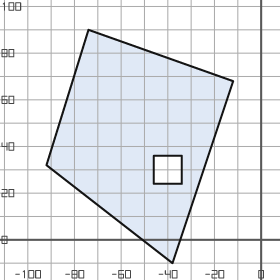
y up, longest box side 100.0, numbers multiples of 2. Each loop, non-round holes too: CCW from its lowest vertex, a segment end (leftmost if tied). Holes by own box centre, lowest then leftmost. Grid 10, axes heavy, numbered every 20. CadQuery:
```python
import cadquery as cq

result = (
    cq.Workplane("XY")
    .moveTo(-38.0, -10.0)
    .lineTo(-12.0, 68.0)
    .lineTo(-74.0, 90.0)
    .lineTo(-92.0, 32.0)
    .close()
    .moveTo(-46.0, 24.0)
    .lineTo(-34.0, 24.0)
    .lineTo(-34.0, 36.0)
    .lineTo(-46.0, 36.0)
    .close()
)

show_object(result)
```